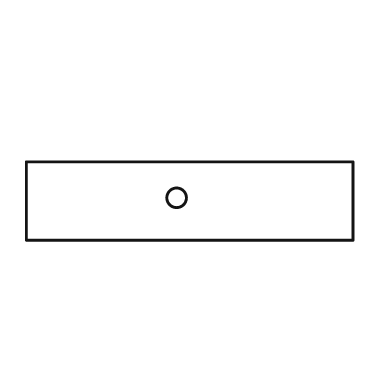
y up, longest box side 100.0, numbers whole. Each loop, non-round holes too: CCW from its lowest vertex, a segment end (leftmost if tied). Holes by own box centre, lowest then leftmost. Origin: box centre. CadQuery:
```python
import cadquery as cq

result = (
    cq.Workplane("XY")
    .moveTo(-50.0, -12.0)
    .lineTo(50.0, -12.0)
    .lineTo(50.0, 12.0)
    .lineTo(-50.0, 12.0)
    .close()
    .moveTo(-4.0, 1.0)
    .circle(3.0)
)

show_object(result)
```